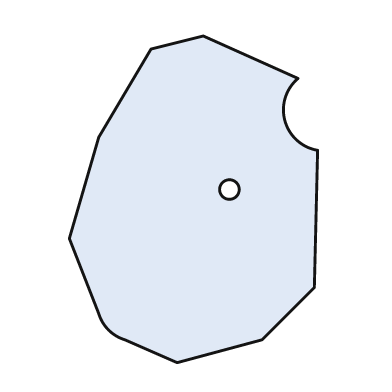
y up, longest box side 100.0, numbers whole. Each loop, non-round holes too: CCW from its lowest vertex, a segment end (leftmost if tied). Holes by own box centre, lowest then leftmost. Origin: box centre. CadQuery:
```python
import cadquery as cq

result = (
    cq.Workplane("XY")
    .moveTo(-5.0, -50.0)
    .lineTo(21.0, -43.0)
    .lineTo(37.0, -27.0)
    .lineTo(38.0, 15.0)
    .threePointArc((28.0, 24.0), (32.0, 37.0))
    .lineTo(3.0, 50.0)
    .lineTo(-13.0, 46.0)
    .lineTo(-29.0, 19.0)
    .lineTo(-38.0, -12.0)
    .lineTo(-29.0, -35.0)
    .threePointArc((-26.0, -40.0), (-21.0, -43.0))
    .close()
    .moveTo(11.0, 3.0)
    .circle(3.0)
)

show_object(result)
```